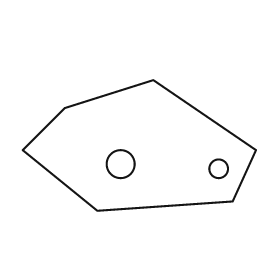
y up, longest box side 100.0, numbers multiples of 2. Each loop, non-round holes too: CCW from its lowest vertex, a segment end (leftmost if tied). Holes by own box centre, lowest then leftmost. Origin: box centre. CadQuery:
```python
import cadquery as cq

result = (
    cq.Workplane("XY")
    .moveTo(-18.0, -28.0)
    .lineTo(40.0, -24.0)
    .lineTo(50.0, -2.0)
    .lineTo(6.0, 28.0)
    .lineTo(-32.0, 16.0)
    .lineTo(-50.0, -2.0)
    .close()
    .moveTo(34.0, -10.0)
    .circle(4.0)
    .moveTo(-8.0, -8.0)
    .circle(6.0)
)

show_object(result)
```